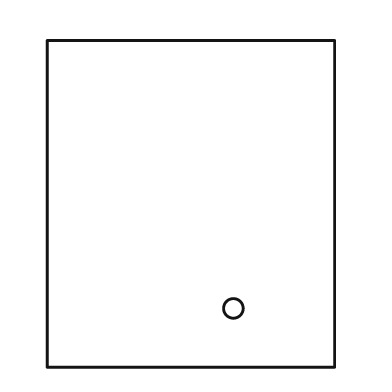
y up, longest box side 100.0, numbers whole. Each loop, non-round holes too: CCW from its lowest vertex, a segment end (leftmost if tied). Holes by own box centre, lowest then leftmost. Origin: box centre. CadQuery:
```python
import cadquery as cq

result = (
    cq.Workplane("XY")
    .moveTo(-44.0, -50.0)
    .lineTo(44.0, -50.0)
    .lineTo(44.0, 50.0)
    .lineTo(-44.0, 50.0)
    .close()
    .moveTo(13.0, -32.0)
    .circle(3.0)
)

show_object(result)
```